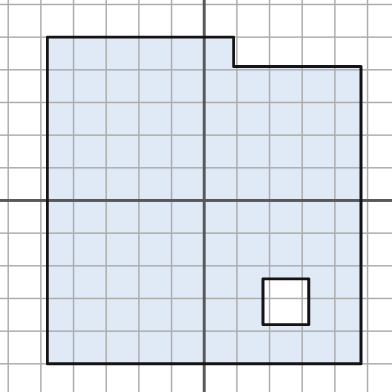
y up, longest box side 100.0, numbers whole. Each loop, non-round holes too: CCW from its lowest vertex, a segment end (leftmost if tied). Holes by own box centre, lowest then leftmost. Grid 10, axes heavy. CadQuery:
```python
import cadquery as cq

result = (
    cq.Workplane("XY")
    .moveTo(-48.0, -50.0)
    .lineTo(48.0, -50.0)
    .lineTo(48.0, 41.0)
    .lineTo(9.0, 41.0)
    .lineTo(9.0, 50.0)
    .lineTo(-48.0, 50.0)
    .close()
    .moveTo(18.0, -38.0)
    .lineTo(32.0, -38.0)
    .lineTo(32.0, -24.0)
    .lineTo(18.0, -24.0)
    .close()
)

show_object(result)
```